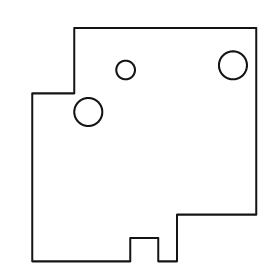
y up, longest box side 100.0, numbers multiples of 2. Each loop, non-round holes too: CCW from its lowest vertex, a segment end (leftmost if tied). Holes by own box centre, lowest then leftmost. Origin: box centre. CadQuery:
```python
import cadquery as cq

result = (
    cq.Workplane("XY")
    .moveTo(-48.0, -50.0)
    .lineTo(-6.0, -50.0)
    .lineTo(-6.0, -40.0)
    .lineTo(6.0, -40.0)
    .lineTo(6.0, -50.0)
    .lineTo(14.0, -50.0)
    .lineTo(14.0, -30.0)
    .lineTo(48.0, -30.0)
    .lineTo(48.0, 50.0)
    .lineTo(-30.0, 50.0)
    .lineTo(-30.0, 22.0)
    .lineTo(-48.0, 22.0)
    .close()
    .moveTo(-24.0, 14.0)
    .circle(6.0)
    .moveTo(-8.0, 32.0)
    .circle(4.0)
    .moveTo(38.0, 34.0)
    .circle(6.0)
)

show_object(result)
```